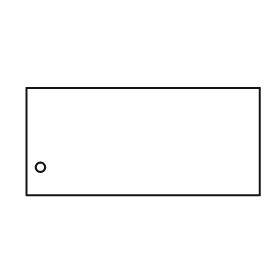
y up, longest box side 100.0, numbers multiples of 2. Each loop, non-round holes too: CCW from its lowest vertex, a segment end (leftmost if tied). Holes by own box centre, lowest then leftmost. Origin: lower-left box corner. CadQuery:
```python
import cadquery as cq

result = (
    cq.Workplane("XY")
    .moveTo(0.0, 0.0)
    .lineTo(100.0, 0.0)
    .lineTo(100.0, 46.0)
    .lineTo(0.0, 46.0)
    .close()
    .moveTo(6.0, 12.0)
    .circle(2.0)
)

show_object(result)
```